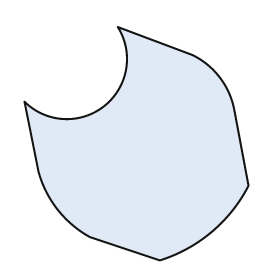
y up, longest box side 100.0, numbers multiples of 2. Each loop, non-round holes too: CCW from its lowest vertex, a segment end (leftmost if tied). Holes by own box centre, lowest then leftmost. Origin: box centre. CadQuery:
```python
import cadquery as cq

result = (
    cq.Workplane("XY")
    .moveTo(10.0, -50.0)
    .threePointArc((32.0, -38.0), (48.0, -18.0))
    .lineTo(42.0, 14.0)
    .threePointArc((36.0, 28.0), (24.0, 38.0))
    .lineTo(-8.0, 50.0)
    .threePointArc((-14.0, 16.0), (-48.0, 18.0))
    .lineTo(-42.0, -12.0)
    .threePointArc((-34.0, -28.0), (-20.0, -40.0))
    .close()
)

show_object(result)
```